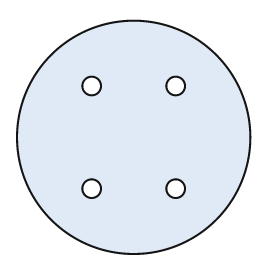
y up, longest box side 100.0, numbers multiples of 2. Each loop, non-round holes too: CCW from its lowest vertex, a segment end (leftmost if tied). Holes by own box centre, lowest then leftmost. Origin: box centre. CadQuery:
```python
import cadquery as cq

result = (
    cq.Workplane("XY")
    .moveTo(0.0, 0.0)
    .circle(50.0)
    .moveTo(-18.0, -22.0)
    .circle(4.0)
    .moveTo(18.0, -22.0)
    .circle(4.0)
    .moveTo(-18.0, 22.0)
    .circle(4.0)
    .moveTo(18.0, 22.0)
    .circle(4.0)
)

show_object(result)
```